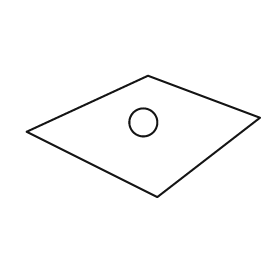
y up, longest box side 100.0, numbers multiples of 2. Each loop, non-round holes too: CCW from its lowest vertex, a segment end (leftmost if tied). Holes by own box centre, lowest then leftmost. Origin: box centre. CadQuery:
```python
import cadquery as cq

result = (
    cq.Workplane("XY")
    .moveTo(6.0, -26.0)
    .lineTo(50.0, 8.0)
    .lineTo(2.0, 26.0)
    .lineTo(-50.0, 2.0)
    .close()
    .moveTo(0.0, 6.0)
    .circle(6.0)
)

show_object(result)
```